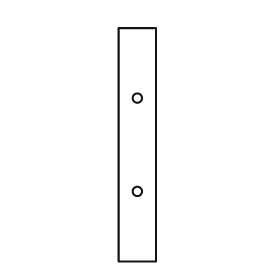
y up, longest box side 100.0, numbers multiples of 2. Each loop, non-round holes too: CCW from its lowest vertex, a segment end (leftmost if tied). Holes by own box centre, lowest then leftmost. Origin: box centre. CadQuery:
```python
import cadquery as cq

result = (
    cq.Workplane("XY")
    .moveTo(-8.0, -50.0)
    .lineTo(8.0, -50.0)
    .lineTo(8.0, 50.0)
    .lineTo(-8.0, 50.0)
    .close()
    .moveTo(0.0, -20.0)
    .circle(2.0)
    .moveTo(0.0, 20.0)
    .circle(2.0)
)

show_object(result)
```